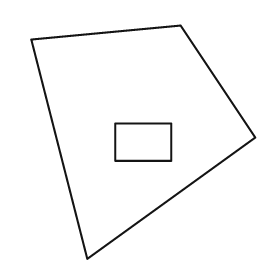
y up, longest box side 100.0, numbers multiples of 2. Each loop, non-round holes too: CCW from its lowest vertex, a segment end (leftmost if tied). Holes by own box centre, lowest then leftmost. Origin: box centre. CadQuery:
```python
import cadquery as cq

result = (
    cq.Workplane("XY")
    .moveTo(-24.0, -50.0)
    .lineTo(48.0, 2.0)
    .lineTo(16.0, 50.0)
    .lineTo(-48.0, 44.0)
    .close()
    .moveTo(-12.0, -8.0)
    .lineTo(12.0, -8.0)
    .lineTo(12.0, 8.0)
    .lineTo(-12.0, 8.0)
    .close()
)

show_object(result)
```